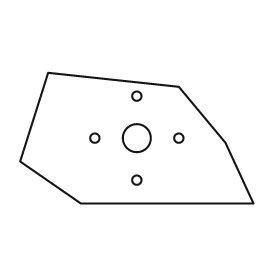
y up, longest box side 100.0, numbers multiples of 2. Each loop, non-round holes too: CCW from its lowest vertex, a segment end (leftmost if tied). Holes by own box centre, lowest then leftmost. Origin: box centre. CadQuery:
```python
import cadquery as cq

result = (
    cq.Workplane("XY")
    .moveTo(-24.0, -28.0)
    .lineTo(50.0, -28.0)
    .lineTo(38.0, -2.0)
    .lineTo(18.0, 22.0)
    .lineTo(-38.0, 28.0)
    .lineTo(-50.0, -10.0)
    .close()
    .moveTo(0.0, -18.0)
    .circle(2.0)
    .moveTo(-18.0, 0.0)
    .circle(2.0)
    .moveTo(0.0, 0.0)
    .circle(6.0)
    .moveTo(18.0, 0.0)
    .circle(2.0)
    .moveTo(0.0, 18.0)
    .circle(2.0)
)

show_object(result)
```